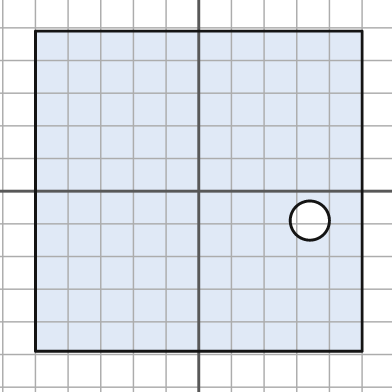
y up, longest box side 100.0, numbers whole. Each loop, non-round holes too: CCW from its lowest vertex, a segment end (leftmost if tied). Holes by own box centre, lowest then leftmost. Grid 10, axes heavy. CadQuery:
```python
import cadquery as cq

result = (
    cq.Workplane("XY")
    .moveTo(-50.0, -49.0)
    .lineTo(50.0, -49.0)
    .lineTo(50.0, 49.0)
    .lineTo(-50.0, 49.0)
    .close()
    .moveTo(34.0, -9.0)
    .circle(6.0)
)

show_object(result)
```